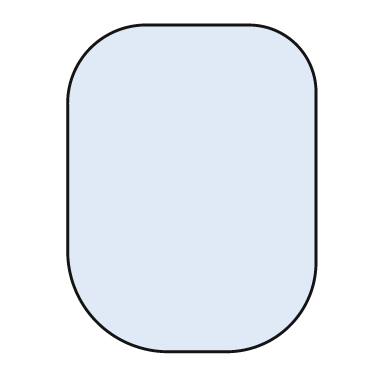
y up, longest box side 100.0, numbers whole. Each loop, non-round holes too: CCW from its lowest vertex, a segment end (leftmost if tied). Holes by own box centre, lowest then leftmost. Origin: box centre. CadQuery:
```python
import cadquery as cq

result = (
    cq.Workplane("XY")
    .moveTo(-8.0, -50.0)
    .lineTo(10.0, -50.0)
    .threePointArc((30.0, -42.0), (38.0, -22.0))
    .lineTo(38.0, 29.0)
    .threePointArc((32.0, 44.0), (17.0, 50.0))
    .lineTo(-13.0, 50.0)
    .threePointArc((-31.0, 43.0), (-38.0, 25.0))
    .lineTo(-38.0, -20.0)
    .threePointArc((-29.0, -41.0), (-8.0, -50.0))
    .close()
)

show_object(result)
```